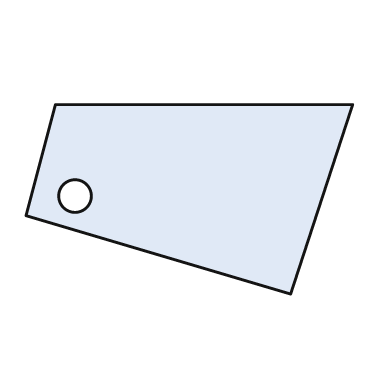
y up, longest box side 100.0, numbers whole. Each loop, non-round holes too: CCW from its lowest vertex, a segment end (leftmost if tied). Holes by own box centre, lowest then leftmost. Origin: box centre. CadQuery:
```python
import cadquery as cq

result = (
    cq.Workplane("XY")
    .moveTo(31.0, -29.0)
    .lineTo(50.0, 29.0)
    .lineTo(-41.0, 29.0)
    .lineTo(-50.0, -5.0)
    .close()
    .moveTo(-35.0, 1.0)
    .circle(5.0)
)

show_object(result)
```